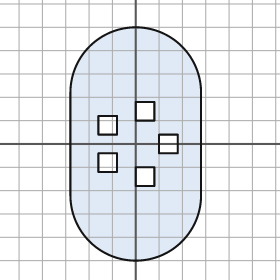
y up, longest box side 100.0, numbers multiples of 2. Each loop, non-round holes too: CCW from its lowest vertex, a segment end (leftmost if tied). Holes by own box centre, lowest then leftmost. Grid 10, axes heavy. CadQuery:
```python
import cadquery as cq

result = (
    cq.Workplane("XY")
    .moveTo(-28.0, -22.0)
    .threePointArc((0.0, -50.0), (28.0, -22.0))
    .lineTo(28.0, 22.0)
    .threePointArc((0.0, 50.0), (-28.0, 22.0))
    .close()
    .moveTo(0.0, -18.0)
    .lineTo(8.0, -18.0)
    .lineTo(8.0, -10.0)
    .lineTo(0.0, -10.0)
    .close()
    .moveTo(-16.0, -12.0)
    .lineTo(-8.0, -12.0)
    .lineTo(-8.0, -4.0)
    .lineTo(-16.0, -4.0)
    .close()
    .moveTo(10.0, -4.0)
    .lineTo(18.0, -4.0)
    .lineTo(18.0, 4.0)
    .lineTo(10.0, 4.0)
    .close()
    .moveTo(-16.0, 4.0)
    .lineTo(-8.0, 4.0)
    .lineTo(-8.0, 12.0)
    .lineTo(-16.0, 12.0)
    .close()
    .moveTo(0.0, 10.0)
    .lineTo(8.0, 10.0)
    .lineTo(8.0, 18.0)
    .lineTo(0.0, 18.0)
    .close()
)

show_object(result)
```